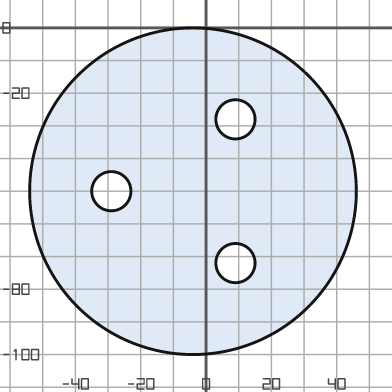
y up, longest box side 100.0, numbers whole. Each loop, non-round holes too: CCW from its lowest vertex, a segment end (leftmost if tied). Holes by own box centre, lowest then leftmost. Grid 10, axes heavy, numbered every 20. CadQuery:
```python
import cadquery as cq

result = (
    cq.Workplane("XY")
    .moveTo(-4.0, -50.0)
    .circle(50.0)
    .moveTo(9.0, -72.0)
    .circle(6.0)
    .moveTo(-29.0, -50.0)
    .circle(6.0)
    .moveTo(9.0, -28.0)
    .circle(6.0)
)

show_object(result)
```